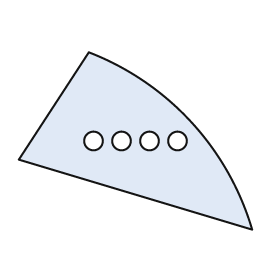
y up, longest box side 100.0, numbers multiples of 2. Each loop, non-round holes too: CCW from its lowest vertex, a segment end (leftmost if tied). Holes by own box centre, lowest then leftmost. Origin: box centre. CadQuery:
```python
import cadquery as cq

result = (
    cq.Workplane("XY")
    .moveTo(50.0, -38.0)
    .threePointArc((24.0, 8.0), (-20.0, 38.0))
    .lineTo(-50.0, -8.0)
    .close()
    .moveTo(-18.0, 0.0)
    .circle(4.0)
    .moveTo(-6.0, 0.0)
    .circle(4.0)
    .moveTo(6.0, 0.0)
    .circle(4.0)
    .moveTo(18.0, 0.0)
    .circle(4.0)
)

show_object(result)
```